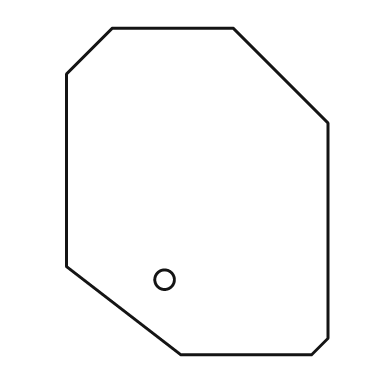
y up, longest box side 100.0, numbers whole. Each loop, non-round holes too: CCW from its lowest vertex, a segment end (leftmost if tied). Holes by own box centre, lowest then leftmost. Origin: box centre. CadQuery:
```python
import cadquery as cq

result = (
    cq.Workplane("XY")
    .moveTo(-5.0, -50.0)
    .lineTo(35.0, -50.0)
    .lineTo(40.0, -45.0)
    .lineTo(40.0, 21.0)
    .lineTo(11.0, 50.0)
    .lineTo(-26.0, 50.0)
    .lineTo(-40.0, 36.0)
    .lineTo(-40.0, -23.0)
    .close()
    .moveTo(-10.0, -27.0)
    .circle(3.0)
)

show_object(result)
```